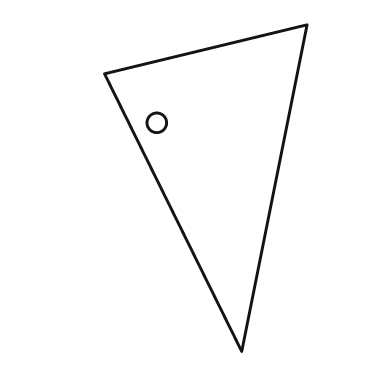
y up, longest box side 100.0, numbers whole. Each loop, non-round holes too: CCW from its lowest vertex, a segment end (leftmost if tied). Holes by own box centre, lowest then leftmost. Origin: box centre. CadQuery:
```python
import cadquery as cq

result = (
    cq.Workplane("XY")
    .moveTo(11.0, -50.0)
    .lineTo(31.0, 50.0)
    .lineTo(-31.0, 35.0)
    .close()
    .moveTo(-15.0, 20.0)
    .circle(3.0)
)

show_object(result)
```